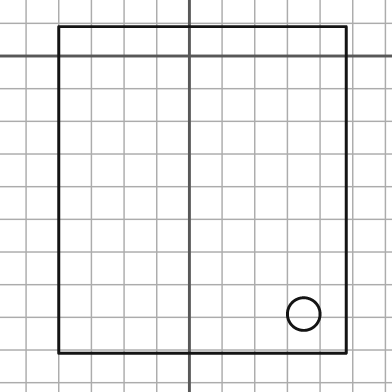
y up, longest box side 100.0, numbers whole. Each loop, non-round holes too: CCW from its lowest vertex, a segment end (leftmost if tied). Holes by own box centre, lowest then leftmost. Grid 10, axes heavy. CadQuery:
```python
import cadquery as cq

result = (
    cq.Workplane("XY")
    .moveTo(-40.0, -91.0)
    .lineTo(48.0, -91.0)
    .lineTo(48.0, 9.0)
    .lineTo(-40.0, 9.0)
    .close()
    .moveTo(35.0, -79.0)
    .circle(5.0)
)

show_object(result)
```